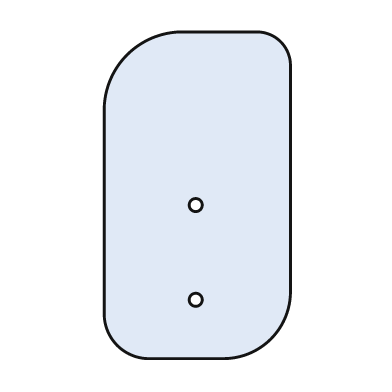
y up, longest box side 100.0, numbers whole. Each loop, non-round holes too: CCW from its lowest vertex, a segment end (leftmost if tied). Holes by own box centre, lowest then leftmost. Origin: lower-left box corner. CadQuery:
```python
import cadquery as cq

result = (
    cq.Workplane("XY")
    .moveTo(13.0, 0.0)
    .lineTo(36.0, 0.0)
    .threePointArc((51.0, 6.0), (57.0, 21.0))
    .lineTo(57.0, 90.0)
    .threePointArc((54.0, 97.0), (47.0, 100.0))
    .lineTo(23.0, 100.0)
    .threePointArc((7.0, 93.0), (0.0, 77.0))
    .lineTo(0.0, 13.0)
    .threePointArc((4.0, 4.0), (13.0, 0.0))
    .close()
    .moveTo(28.0, 18.0)
    .circle(2.0)
    .moveTo(28.0, 47.0)
    .circle(2.0)
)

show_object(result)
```